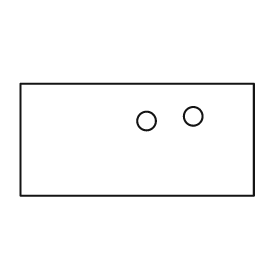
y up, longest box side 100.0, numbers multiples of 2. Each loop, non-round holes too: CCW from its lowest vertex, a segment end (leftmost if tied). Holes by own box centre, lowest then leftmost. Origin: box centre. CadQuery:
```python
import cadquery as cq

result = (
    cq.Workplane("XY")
    .moveTo(-50.0, -24.0)
    .lineTo(50.0, -24.0)
    .lineTo(50.0, 24.0)
    .lineTo(-50.0, 24.0)
    .close()
    .moveTo(4.0, 8.0)
    .circle(4.0)
    .moveTo(24.0, 10.0)
    .circle(4.0)
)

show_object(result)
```